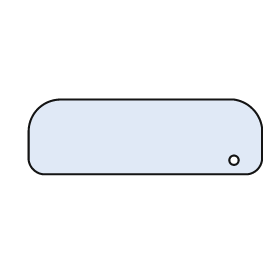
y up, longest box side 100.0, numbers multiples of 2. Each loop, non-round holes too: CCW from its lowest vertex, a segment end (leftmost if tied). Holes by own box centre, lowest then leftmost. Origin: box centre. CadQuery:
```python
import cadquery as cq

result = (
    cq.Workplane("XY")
    .moveTo(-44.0, -16.0)
    .lineTo(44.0, -16.0)
    .threePointArc((48.0, -14.0), (50.0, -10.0))
    .lineTo(50.0, 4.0)
    .threePointArc((46.0, 12.0), (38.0, 16.0))
    .lineTo(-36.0, 16.0)
    .threePointArc((-46.0, 12.0), (-50.0, 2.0))
    .lineTo(-50.0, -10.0)
    .threePointArc((-48.0, -14.0), (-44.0, -16.0))
    .close()
    .moveTo(38.0, -10.0)
    .circle(2.0)
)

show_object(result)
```